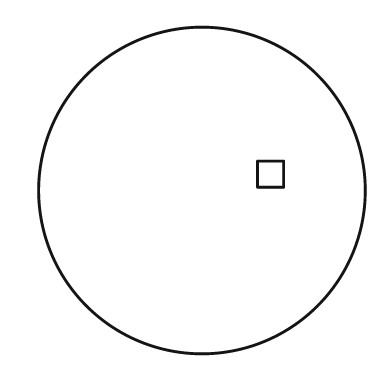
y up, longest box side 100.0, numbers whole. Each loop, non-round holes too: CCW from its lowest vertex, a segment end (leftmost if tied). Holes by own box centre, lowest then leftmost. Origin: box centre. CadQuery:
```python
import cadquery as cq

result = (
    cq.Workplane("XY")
    .moveTo(0.0, 0.0)
    .circle(50.0)
    .moveTo(17.0, 1.0)
    .lineTo(25.0, 1.0)
    .lineTo(25.0, 9.0)
    .lineTo(17.0, 9.0)
    .close()
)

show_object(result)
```